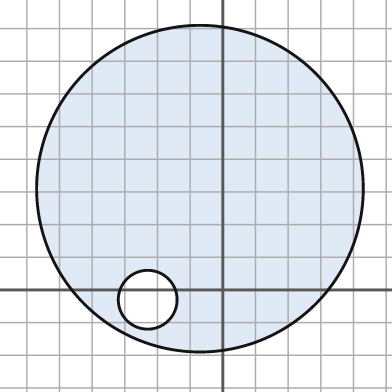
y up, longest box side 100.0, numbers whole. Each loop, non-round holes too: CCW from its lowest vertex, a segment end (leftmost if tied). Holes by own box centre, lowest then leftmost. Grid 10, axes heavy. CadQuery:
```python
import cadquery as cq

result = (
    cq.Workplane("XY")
    .moveTo(-7.0, 31.0)
    .circle(50.0)
    .moveTo(-23.0, -3.0)
    .circle(9.0)
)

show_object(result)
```